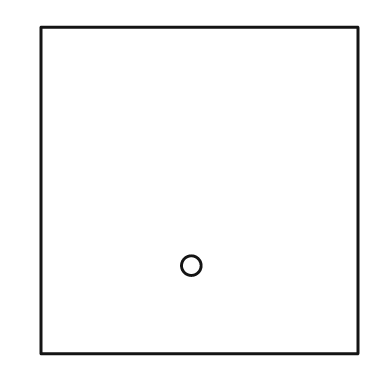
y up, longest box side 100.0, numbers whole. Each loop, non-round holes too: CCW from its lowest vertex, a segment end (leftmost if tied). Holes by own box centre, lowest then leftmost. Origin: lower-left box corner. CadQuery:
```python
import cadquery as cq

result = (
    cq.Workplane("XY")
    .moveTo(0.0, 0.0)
    .lineTo(97.0, 0.0)
    .lineTo(97.0, 100.0)
    .lineTo(0.0, 100.0)
    .close()
    .moveTo(46.0, 27.0)
    .circle(3.0)
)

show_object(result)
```